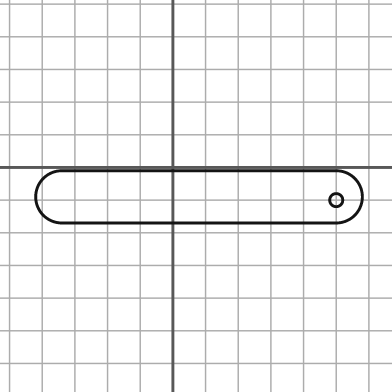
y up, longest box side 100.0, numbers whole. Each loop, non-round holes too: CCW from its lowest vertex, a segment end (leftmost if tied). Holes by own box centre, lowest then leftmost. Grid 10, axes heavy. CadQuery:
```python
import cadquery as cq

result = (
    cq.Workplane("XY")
    .moveTo(-34.0, -17.0)
    .lineTo(50.0, -17.0)
    .threePointArc((58.0, -9.0), (50.0, -1.0))
    .lineTo(-34.0, -1.0)
    .threePointArc((-42.0, -9.0), (-34.0, -17.0))
    .close()
    .moveTo(50.0, -10.0)
    .circle(2.0)
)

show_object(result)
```